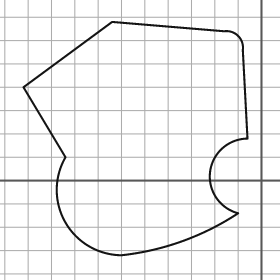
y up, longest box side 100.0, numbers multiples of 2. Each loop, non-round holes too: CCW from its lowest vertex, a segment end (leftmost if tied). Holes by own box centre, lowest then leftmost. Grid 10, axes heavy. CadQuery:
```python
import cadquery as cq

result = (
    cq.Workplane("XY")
    .moveTo(-60.0, -32.0)
    .threePointArc((-34.0, -26.0), (-10.0, -14.0))
    .threePointArc((-22.0, 4.0), (-6.0, 18.0))
    .lineTo(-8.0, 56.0)
    .threePointArc((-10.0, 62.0), (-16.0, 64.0))
    .lineTo(-64.0, 68.0)
    .lineTo(-102.0, 40.0)
    .lineTo(-84.0, 10.0)
    .threePointArc((-84.0, -18.0), (-60.0, -32.0))
    .close()
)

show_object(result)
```